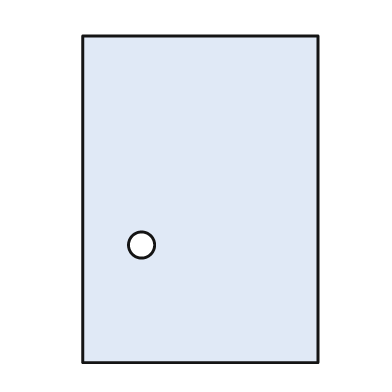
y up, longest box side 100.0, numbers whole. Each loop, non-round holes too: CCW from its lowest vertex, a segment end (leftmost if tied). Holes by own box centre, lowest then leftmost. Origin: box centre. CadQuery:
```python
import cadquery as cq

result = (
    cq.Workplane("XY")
    .moveTo(-36.0, -50.0)
    .lineTo(36.0, -50.0)
    .lineTo(36.0, 50.0)
    .lineTo(-36.0, 50.0)
    .close()
    .moveTo(-18.0, -14.0)
    .circle(4.0)
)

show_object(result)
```